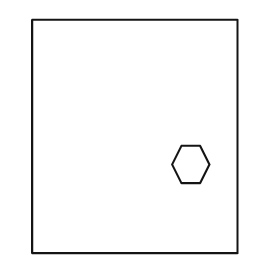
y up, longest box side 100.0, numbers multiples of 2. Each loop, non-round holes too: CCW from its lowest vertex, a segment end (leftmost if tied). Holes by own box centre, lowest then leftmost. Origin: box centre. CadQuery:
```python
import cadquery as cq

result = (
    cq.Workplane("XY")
    .moveTo(-44.0, -50.0)
    .lineTo(44.0, -50.0)
    .lineTo(44.0, 50.0)
    .lineTo(-44.0, 50.0)
    .close()
    .moveTo(20.0, -20.0)
    .lineTo(28.0, -20.0)
    .lineTo(32.0, -12.0)
    .lineTo(28.0, -4.0)
    .lineTo(20.0, -4.0)
    .lineTo(16.0, -12.0)
    .close()
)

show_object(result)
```